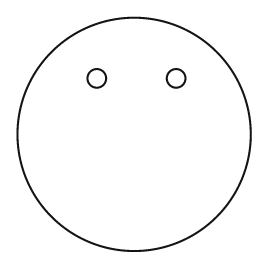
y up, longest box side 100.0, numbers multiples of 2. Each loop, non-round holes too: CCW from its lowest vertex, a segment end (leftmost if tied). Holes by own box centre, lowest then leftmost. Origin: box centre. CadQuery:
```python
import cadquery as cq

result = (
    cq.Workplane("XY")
    .moveTo(0.0, 0.0)
    .circle(50.0)
    .moveTo(-16.0, 24.0)
    .circle(4.0)
    .moveTo(18.0, 24.0)
    .circle(4.0)
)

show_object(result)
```